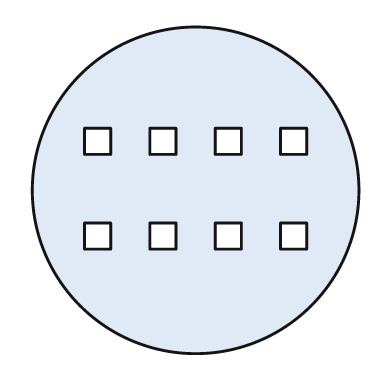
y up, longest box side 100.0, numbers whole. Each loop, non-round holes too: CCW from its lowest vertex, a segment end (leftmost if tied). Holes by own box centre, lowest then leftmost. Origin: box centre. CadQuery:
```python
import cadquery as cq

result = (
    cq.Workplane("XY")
    .moveTo(0.0, 0.0)
    .circle(50.0)
    .moveTo(-34.0, -18.0)
    .lineTo(-26.0, -18.0)
    .lineTo(-26.0, -10.0)
    .lineTo(-34.0, -10.0)
    .close()
    .moveTo(-14.0, -18.0)
    .lineTo(-6.0, -18.0)
    .lineTo(-6.0, -10.0)
    .lineTo(-14.0, -10.0)
    .close()
    .moveTo(6.0, -18.0)
    .lineTo(14.0, -18.0)
    .lineTo(14.0, -10.0)
    .lineTo(6.0, -10.0)
    .close()
    .moveTo(26.0, -18.0)
    .lineTo(34.0, -18.0)
    .lineTo(34.0, -10.0)
    .lineTo(26.0, -10.0)
    .close()
    .moveTo(-34.0, 11.0)
    .lineTo(-26.0, 11.0)
    .lineTo(-26.0, 19.0)
    .lineTo(-34.0, 19.0)
    .close()
    .moveTo(-14.0, 11.0)
    .lineTo(-6.0, 11.0)
    .lineTo(-6.0, 19.0)
    .lineTo(-14.0, 19.0)
    .close()
    .moveTo(6.0, 11.0)
    .lineTo(14.0, 11.0)
    .lineTo(14.0, 19.0)
    .lineTo(6.0, 19.0)
    .close()
    .moveTo(26.0, 11.0)
    .lineTo(34.0, 11.0)
    .lineTo(34.0, 19.0)
    .lineTo(26.0, 19.0)
    .close()
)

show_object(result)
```